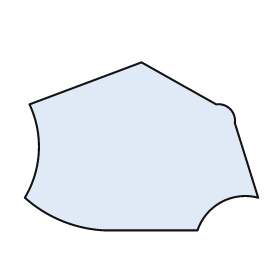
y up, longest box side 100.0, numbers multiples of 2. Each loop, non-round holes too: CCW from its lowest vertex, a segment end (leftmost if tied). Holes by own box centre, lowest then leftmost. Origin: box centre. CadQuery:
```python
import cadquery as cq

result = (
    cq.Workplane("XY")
    .moveTo(-16.0, -36.0)
    .lineTo(24.0, -36.0)
    .threePointArc((34.0, -24.0), (50.0, -22.0))
    .lineTo(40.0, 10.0)
    .threePointArc((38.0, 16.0), (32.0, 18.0))
    .lineTo(0.0, 36.0)
    .lineTo(-48.0, 18.0)
    .threePointArc((-44.0, -2.0), (-50.0, -22.0))
    .threePointArc((-34.0, -32.0), (-16.0, -36.0))
    .close()
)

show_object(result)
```